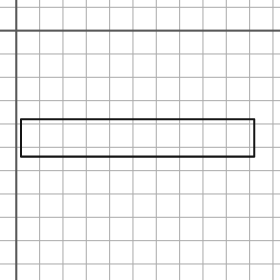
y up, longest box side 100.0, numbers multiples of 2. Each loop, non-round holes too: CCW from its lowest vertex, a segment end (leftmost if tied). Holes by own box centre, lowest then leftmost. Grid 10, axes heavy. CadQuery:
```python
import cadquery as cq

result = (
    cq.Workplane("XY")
    .moveTo(2.0, -54.0)
    .lineTo(102.0, -54.0)
    .lineTo(102.0, -38.0)
    .lineTo(2.0, -38.0)
    .close()
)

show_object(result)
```